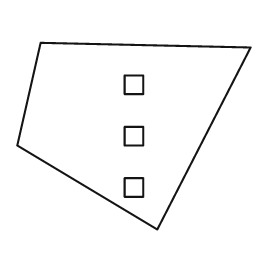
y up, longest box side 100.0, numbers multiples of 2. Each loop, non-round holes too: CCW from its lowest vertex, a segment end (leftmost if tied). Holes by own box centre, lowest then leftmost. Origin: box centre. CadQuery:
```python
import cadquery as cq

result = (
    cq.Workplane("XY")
    .moveTo(10.0, -40.0)
    .lineTo(50.0, 38.0)
    .lineTo(-40.0, 40.0)
    .lineTo(-50.0, -4.0)
    .close()
    .moveTo(-4.0, -26.0)
    .lineTo(4.0, -26.0)
    .lineTo(4.0, -18.0)
    .lineTo(-4.0, -18.0)
    .close()
    .moveTo(-4.0, -4.0)
    .lineTo(4.0, -4.0)
    .lineTo(4.0, 4.0)
    .lineTo(-4.0, 4.0)
    .close()
    .moveTo(-4.0, 18.0)
    .lineTo(4.0, 18.0)
    .lineTo(4.0, 26.0)
    .lineTo(-4.0, 26.0)
    .close()
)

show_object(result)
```